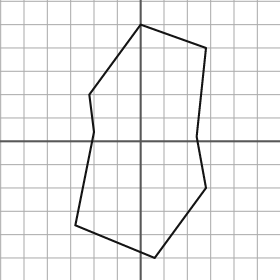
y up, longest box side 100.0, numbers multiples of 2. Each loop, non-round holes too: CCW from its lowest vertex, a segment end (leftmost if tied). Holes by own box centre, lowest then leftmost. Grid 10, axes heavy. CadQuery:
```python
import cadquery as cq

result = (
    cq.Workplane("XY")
    .moveTo(6.0, -50.0)
    .lineTo(28.0, -20.0)
    .lineTo(24.0, 2.0)
    .lineTo(28.0, 40.0)
    .lineTo(0.0, 50.0)
    .lineTo(-22.0, 20.0)
    .lineTo(-20.0, 4.0)
    .lineTo(-28.0, -36.0)
    .close()
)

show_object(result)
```